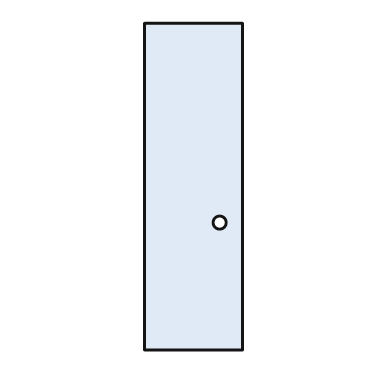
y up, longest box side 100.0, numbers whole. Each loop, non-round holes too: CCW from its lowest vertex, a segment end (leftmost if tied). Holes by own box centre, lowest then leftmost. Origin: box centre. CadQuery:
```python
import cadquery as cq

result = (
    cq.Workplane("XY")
    .moveTo(-15.0, -50.0)
    .lineTo(15.0, -50.0)
    .lineTo(15.0, 50.0)
    .lineTo(-15.0, 50.0)
    .close()
    .moveTo(8.0, -11.0)
    .circle(2.0)
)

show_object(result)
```